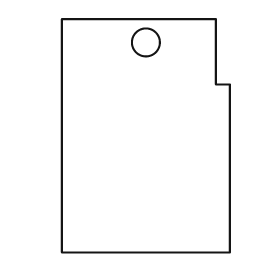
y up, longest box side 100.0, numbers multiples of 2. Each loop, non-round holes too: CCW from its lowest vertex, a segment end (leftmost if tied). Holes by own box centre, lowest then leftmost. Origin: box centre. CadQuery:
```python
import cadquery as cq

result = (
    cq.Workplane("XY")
    .moveTo(-36.0, -50.0)
    .lineTo(36.0, -50.0)
    .lineTo(36.0, 22.0)
    .lineTo(30.0, 22.0)
    .lineTo(30.0, 50.0)
    .lineTo(-36.0, 50.0)
    .close()
    .moveTo(0.0, 40.0)
    .circle(6.0)
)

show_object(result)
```